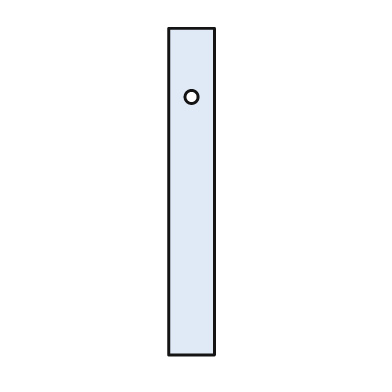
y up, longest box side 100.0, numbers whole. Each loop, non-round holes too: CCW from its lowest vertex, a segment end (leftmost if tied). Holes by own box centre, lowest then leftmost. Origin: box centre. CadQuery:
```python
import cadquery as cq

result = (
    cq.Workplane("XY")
    .moveTo(-7.0, -50.0)
    .lineTo(7.0, -50.0)
    .lineTo(7.0, 50.0)
    .lineTo(-7.0, 50.0)
    .close()
    .moveTo(0.0, 29.0)
    .circle(2.0)
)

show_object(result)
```